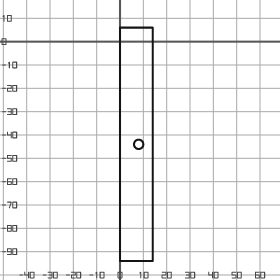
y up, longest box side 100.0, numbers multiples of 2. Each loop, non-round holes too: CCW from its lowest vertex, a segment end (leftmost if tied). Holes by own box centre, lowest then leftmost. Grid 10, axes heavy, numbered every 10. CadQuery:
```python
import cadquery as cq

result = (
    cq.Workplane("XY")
    .moveTo(0.0, -94.0)
    .lineTo(14.0, -94.0)
    .lineTo(14.0, 6.0)
    .lineTo(0.0, 6.0)
    .close()
    .moveTo(8.0, -44.0)
    .circle(2.0)
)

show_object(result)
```